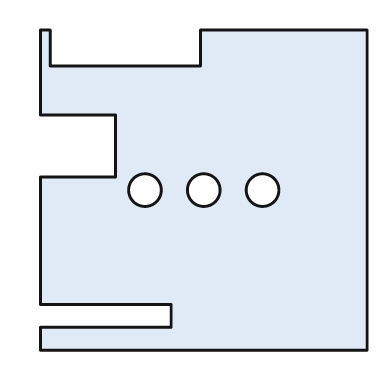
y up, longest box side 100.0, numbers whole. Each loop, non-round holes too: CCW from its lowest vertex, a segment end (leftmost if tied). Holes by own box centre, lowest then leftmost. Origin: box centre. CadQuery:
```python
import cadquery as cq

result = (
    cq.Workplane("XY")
    .moveTo(-50.0, -49.0)
    .lineTo(50.0, -49.0)
    .lineTo(50.0, 49.0)
    .lineTo(-1.0, 49.0)
    .lineTo(-1.0, 38.0)
    .lineTo(-47.0, 38.0)
    .lineTo(-47.0, 49.0)
    .lineTo(-50.0, 49.0)
    .lineTo(-50.0, 23.0)
    .lineTo(-27.0, 23.0)
    .lineTo(-27.0, 4.0)
    .lineTo(-50.0, 4.0)
    .lineTo(-50.0, -35.0)
    .lineTo(-10.0, -35.0)
    .lineTo(-10.0, -42.0)
    .lineTo(-50.0, -42.0)
    .close()
    .moveTo(-18.0, 0.0)
    .circle(5.0)
    .moveTo(0.0, 0.0)
    .circle(5.0)
    .moveTo(18.0, 0.0)
    .circle(5.0)
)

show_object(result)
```